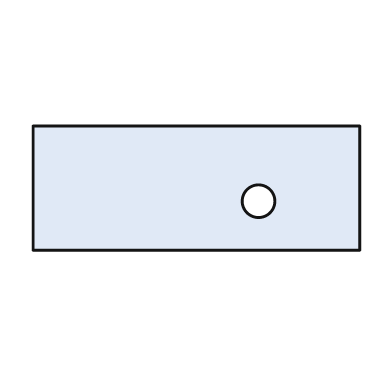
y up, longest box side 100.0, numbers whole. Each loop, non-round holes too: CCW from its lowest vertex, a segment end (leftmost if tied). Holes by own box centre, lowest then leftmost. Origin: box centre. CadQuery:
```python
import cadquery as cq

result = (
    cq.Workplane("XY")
    .moveTo(-50.0, -19.0)
    .lineTo(50.0, -19.0)
    .lineTo(50.0, 19.0)
    .lineTo(-50.0, 19.0)
    .close()
    .moveTo(19.0, -4.0)
    .circle(5.0)
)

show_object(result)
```